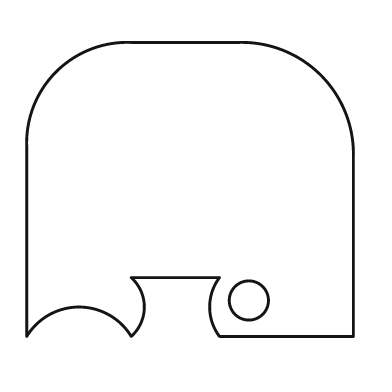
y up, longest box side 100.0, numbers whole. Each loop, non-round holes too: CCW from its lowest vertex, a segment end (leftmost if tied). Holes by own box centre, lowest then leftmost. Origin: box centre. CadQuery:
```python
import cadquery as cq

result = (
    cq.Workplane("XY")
    .moveTo(-50.0, -45.0)
    .threePointArc((-34.0, -36.0), (-18.0, -45.0))
    .threePointArc((-14.0, -36.0), (-18.0, -27.0))
    .lineTo(9.0, -27.0)
    .threePointArc((6.0, -36.0), (9.0, -45.0))
    .lineTo(50.0, -45.0)
    .lineTo(50.0, 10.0)
    .threePointArc((40.0, 35.0), (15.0, 45.0))
    .lineTo(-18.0, 45.0)
    .threePointArc((-41.0, 36.0), (-50.0, 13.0))
    .close()
    .moveTo(18.0, -34.0)
    .circle(6.0)
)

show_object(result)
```